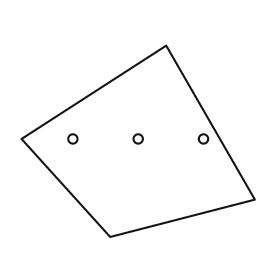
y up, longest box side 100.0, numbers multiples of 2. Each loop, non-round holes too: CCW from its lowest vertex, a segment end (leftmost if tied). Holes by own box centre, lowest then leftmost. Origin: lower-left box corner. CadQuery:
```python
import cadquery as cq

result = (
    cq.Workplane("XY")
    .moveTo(38.0, 0.0)
    .lineTo(100.0, 16.0)
    .lineTo(62.0, 82.0)
    .lineTo(0.0, 42.0)
    .close()
    .moveTo(22.0, 42.0)
    .circle(2.0)
    .moveTo(50.0, 42.0)
    .circle(2.0)
    .moveTo(78.0, 42.0)
    .circle(2.0)
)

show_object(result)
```